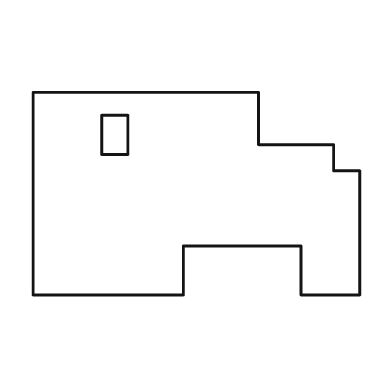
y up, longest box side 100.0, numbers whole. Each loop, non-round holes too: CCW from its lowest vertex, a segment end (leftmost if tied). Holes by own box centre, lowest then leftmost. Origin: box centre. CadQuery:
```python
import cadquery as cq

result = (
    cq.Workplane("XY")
    .moveTo(-50.0, -31.0)
    .lineTo(-4.0, -31.0)
    .lineTo(-4.0, -16.0)
    .lineTo(32.0, -16.0)
    .lineTo(32.0, -31.0)
    .lineTo(50.0, -31.0)
    .lineTo(50.0, 7.0)
    .lineTo(42.0, 7.0)
    .lineTo(42.0, 15.0)
    .lineTo(19.0, 15.0)
    .lineTo(19.0, 31.0)
    .lineTo(-50.0, 31.0)
    .close()
    .moveTo(-29.0, 12.0)
    .lineTo(-21.0, 12.0)
    .lineTo(-21.0, 24.0)
    .lineTo(-29.0, 24.0)
    .close()
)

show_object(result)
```